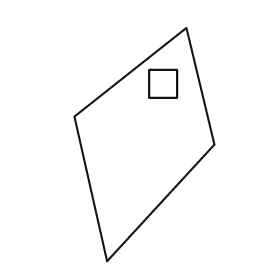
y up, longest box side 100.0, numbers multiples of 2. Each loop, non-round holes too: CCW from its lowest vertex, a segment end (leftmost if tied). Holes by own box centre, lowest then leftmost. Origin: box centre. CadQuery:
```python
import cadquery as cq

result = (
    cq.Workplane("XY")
    .moveTo(-16.0, -50.0)
    .lineTo(30.0, 0.0)
    .lineTo(18.0, 50.0)
    .lineTo(-30.0, 12.0)
    .close()
    .moveTo(2.0, 20.0)
    .lineTo(14.0, 20.0)
    .lineTo(14.0, 32.0)
    .lineTo(2.0, 32.0)
    .close()
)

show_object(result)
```